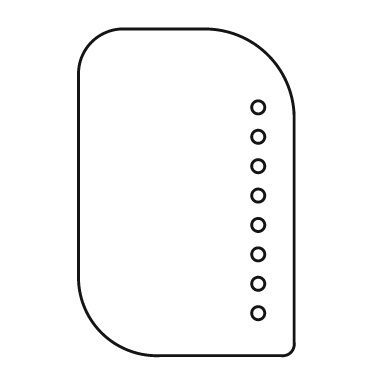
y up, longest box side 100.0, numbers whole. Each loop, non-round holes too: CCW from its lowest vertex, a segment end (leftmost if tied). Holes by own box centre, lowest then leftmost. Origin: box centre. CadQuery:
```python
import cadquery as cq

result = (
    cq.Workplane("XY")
    .moveTo(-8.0, -50.0)
    .lineTo(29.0, -50.0)
    .threePointArc((32.0, -49.0), (33.0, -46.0))
    .lineTo(33.0, 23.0)
    .threePointArc((25.0, 42.0), (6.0, 50.0))
    .lineTo(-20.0, 50.0)
    .threePointArc((-29.0, 46.0), (-33.0, 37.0))
    .lineTo(-33.0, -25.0)
    .threePointArc((-26.0, -43.0), (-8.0, -50.0))
    .close()
    .moveTo(22.0, -37.0)
    .circle(2.0)
    .moveTo(22.0, -28.0)
    .circle(2.0)
    .moveTo(22.0, -19.0)
    .circle(2.0)
    .moveTo(22.0, -10.0)
    .circle(2.0)
    .moveTo(22.0, -1.0)
    .circle(2.0)
    .moveTo(22.0, 8.0)
    .circle(2.0)
    .moveTo(22.0, 17.0)
    .circle(2.0)
    .moveTo(22.0, 26.0)
    .circle(2.0)
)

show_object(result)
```